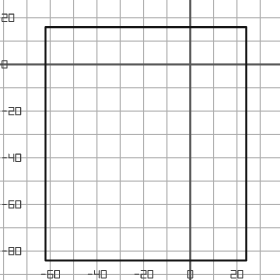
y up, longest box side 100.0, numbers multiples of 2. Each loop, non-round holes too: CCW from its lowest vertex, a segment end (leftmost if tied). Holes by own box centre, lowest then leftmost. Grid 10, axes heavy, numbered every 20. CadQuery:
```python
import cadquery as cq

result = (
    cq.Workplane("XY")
    .moveTo(-62.0, -84.0)
    .lineTo(24.0, -84.0)
    .lineTo(24.0, 16.0)
    .lineTo(-62.0, 16.0)
    .close()
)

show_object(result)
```